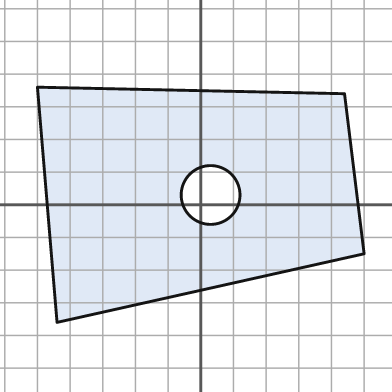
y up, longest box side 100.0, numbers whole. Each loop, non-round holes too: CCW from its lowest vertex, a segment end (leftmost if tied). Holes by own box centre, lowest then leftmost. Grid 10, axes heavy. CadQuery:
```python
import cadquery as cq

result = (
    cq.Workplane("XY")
    .moveTo(-44.0, -36.0)
    .lineTo(50.0, -15.0)
    .lineTo(44.0, 34.0)
    .lineTo(-50.0, 36.0)
    .close()
    .moveTo(3.0, 3.0)
    .circle(9.0)
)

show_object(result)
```